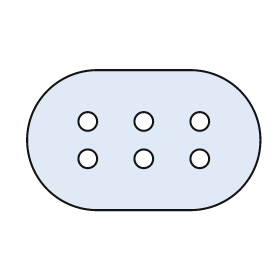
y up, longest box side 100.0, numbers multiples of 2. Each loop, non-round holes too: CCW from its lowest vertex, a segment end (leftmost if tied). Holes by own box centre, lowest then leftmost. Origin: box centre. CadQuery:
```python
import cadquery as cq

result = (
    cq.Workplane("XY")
    .moveTo(-20.0, -30.0)
    .lineTo(20.0, -30.0)
    .threePointArc((50.0, 0.0), (20.0, 30.0))
    .lineTo(-20.0, 30.0)
    .threePointArc((-50.0, 0.0), (-20.0, -30.0))
    .close()
    .moveTo(-24.0, -8.0)
    .circle(4.0)
    .moveTo(0.0, -8.0)
    .circle(4.0)
    .moveTo(24.0, -8.0)
    .circle(4.0)
    .moveTo(-24.0, 8.0)
    .circle(4.0)
    .moveTo(0.0, 8.0)
    .circle(4.0)
    .moveTo(24.0, 8.0)
    .circle(4.0)
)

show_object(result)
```